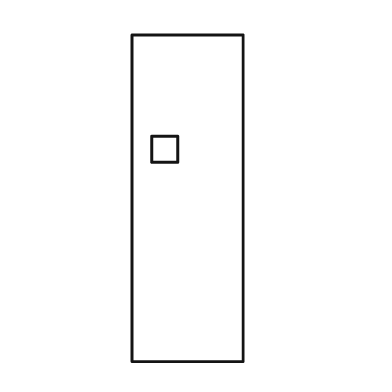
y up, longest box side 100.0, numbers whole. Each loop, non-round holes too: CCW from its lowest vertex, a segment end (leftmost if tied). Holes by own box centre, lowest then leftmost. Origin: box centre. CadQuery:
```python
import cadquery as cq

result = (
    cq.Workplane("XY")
    .moveTo(-17.0, -50.0)
    .lineTo(17.0, -50.0)
    .lineTo(17.0, 50.0)
    .lineTo(-17.0, 50.0)
    .close()
    .moveTo(-11.0, 11.0)
    .lineTo(-3.0, 11.0)
    .lineTo(-3.0, 19.0)
    .lineTo(-11.0, 19.0)
    .close()
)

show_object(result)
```